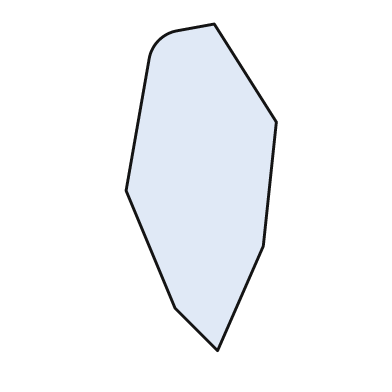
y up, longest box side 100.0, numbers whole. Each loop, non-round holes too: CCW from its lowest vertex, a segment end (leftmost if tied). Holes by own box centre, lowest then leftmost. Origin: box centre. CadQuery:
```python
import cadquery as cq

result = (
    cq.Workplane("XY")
    .moveTo(5.0, -50.0)
    .lineTo(19.0, -18.0)
    .lineTo(23.0, 20.0)
    .lineTo(4.0, 50.0)
    .lineTo(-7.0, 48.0)
    .threePointArc((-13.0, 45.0), (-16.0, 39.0))
    .lineTo(-23.0, -1.0)
    .lineTo(-8.0, -37.0)
    .close()
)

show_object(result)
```